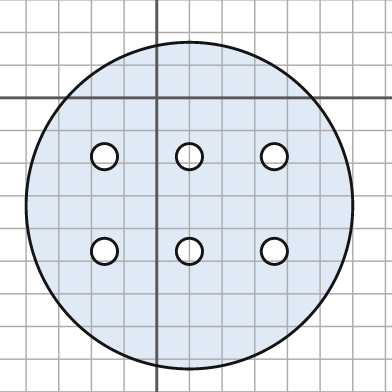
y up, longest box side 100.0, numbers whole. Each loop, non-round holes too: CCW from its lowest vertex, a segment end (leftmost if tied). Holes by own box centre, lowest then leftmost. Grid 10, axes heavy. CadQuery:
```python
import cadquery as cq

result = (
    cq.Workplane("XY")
    .moveTo(10.0, -33.0)
    .circle(50.0)
    .moveTo(-16.0, -47.0)
    .circle(4.0)
    .moveTo(10.0, -47.0)
    .circle(4.0)
    .moveTo(36.0, -47.0)
    .circle(4.0)
    .moveTo(-16.0, -18.0)
    .circle(4.0)
    .moveTo(10.0, -18.0)
    .circle(4.0)
    .moveTo(36.0, -18.0)
    .circle(4.0)
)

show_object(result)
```